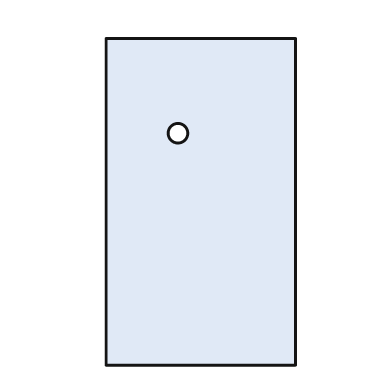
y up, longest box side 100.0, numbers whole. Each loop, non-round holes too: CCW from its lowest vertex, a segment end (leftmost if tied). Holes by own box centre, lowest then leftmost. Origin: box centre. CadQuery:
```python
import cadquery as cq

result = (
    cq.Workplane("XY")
    .moveTo(-29.0, -50.0)
    .lineTo(29.0, -50.0)
    .lineTo(29.0, 50.0)
    .lineTo(-29.0, 50.0)
    .close()
    .moveTo(-7.0, 21.0)
    .circle(3.0)
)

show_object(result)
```